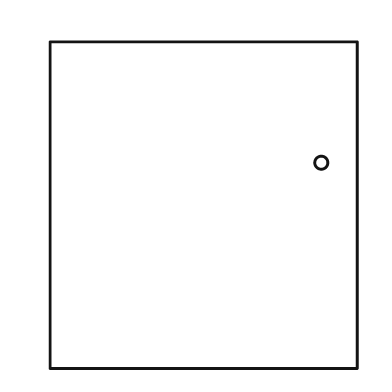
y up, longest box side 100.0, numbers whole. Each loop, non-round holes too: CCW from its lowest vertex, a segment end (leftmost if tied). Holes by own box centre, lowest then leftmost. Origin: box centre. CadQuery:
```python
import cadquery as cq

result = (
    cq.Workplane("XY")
    .moveTo(-47.0, -50.0)
    .lineTo(47.0, -50.0)
    .lineTo(47.0, 50.0)
    .lineTo(-47.0, 50.0)
    .close()
    .moveTo(36.0, 13.0)
    .circle(2.0)
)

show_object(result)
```